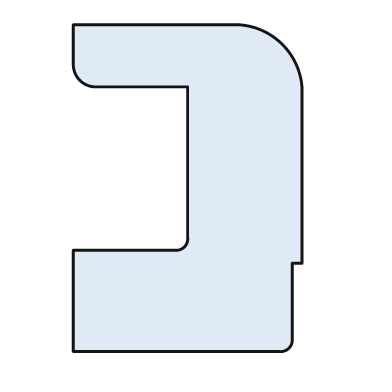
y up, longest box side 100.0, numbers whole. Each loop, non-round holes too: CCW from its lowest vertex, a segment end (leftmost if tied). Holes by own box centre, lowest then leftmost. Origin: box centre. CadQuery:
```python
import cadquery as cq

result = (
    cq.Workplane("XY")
    .moveTo(-35.0, -50.0)
    .lineTo(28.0, -50.0)
    .threePointArc((31.0, -49.0), (32.0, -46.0))
    .lineTo(32.0, -23.0)
    .lineTo(35.0, -23.0)
    .lineTo(35.0, 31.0)
    .threePointArc((29.0, 44.0), (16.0, 50.0))
    .lineTo(-35.0, 50.0)
    .lineTo(-35.0, 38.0)
    .threePointArc((-33.0, 33.0), (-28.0, 31.0))
    .lineTo(0.0, 31.0)
    .lineTo(0.0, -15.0)
    .threePointArc((-1.0, -18.0), (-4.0, -19.0))
    .lineTo(-35.0, -19.0)
    .close()
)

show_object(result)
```